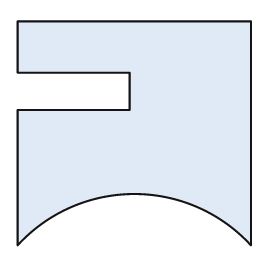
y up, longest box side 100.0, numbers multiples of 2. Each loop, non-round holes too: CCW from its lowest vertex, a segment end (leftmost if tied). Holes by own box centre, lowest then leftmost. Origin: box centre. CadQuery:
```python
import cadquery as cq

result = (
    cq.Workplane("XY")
    .moveTo(-50.0, -48.0)
    .threePointArc((0.0, -26.0), (50.0, -48.0))
    .lineTo(50.0, 48.0)
    .lineTo(-50.0, 48.0)
    .lineTo(-50.0, 26.0)
    .lineTo(-2.0, 26.0)
    .lineTo(-2.0, 10.0)
    .lineTo(-50.0, 10.0)
    .close()
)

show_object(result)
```